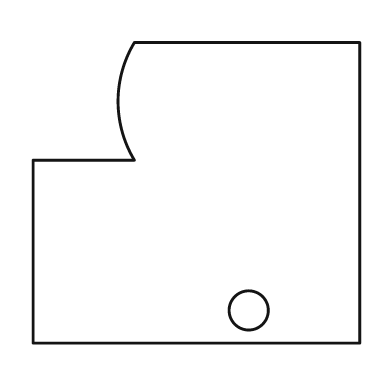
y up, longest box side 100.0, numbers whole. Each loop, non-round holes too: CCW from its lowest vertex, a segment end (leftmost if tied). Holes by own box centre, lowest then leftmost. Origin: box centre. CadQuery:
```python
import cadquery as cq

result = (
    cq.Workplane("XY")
    .moveTo(-50.0, -46.0)
    .lineTo(50.0, -46.0)
    .lineTo(50.0, 46.0)
    .lineTo(-19.0, 46.0)
    .threePointArc((-24.0, 28.0), (-19.0, 10.0))
    .lineTo(-50.0, 10.0)
    .close()
    .moveTo(16.0, -36.0)
    .circle(6.0)
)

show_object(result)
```